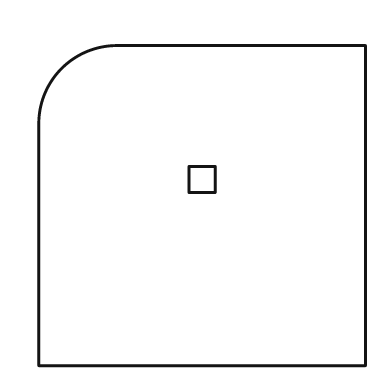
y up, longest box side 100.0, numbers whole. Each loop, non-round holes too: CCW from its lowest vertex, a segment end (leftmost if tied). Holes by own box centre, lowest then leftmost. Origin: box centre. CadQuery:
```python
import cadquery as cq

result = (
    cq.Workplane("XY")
    .moveTo(-50.0, -49.0)
    .lineTo(50.0, -49.0)
    .lineTo(50.0, 49.0)
    .lineTo(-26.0, 49.0)
    .threePointArc((-43.0, 42.0), (-50.0, 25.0))
    .close()
    .moveTo(-4.0, 4.0)
    .lineTo(4.0, 4.0)
    .lineTo(4.0, 12.0)
    .lineTo(-4.0, 12.0)
    .close()
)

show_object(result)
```